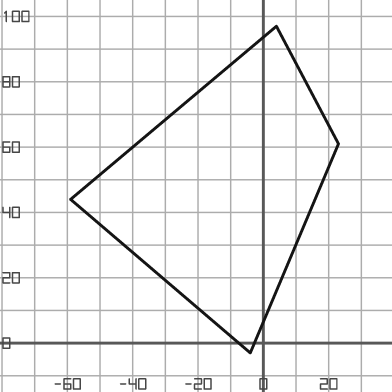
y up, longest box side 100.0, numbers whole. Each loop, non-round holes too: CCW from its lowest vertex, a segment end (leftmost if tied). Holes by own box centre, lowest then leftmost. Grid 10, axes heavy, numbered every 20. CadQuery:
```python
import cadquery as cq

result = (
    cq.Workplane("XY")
    .moveTo(-4.0, -3.0)
    .lineTo(23.0, 61.0)
    .lineTo(4.0, 97.0)
    .lineTo(-59.0, 44.0)
    .close()
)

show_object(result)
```